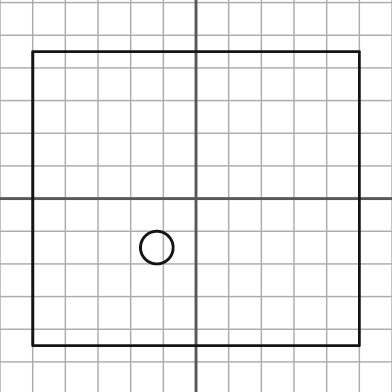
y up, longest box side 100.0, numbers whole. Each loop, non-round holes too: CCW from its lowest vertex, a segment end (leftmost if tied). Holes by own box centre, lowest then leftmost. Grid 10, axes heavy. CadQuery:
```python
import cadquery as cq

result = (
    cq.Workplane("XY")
    .moveTo(-50.0, -45.0)
    .lineTo(50.0, -45.0)
    .lineTo(50.0, 45.0)
    .lineTo(-50.0, 45.0)
    .close()
    .moveTo(-12.0, -15.0)
    .circle(5.0)
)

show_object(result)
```